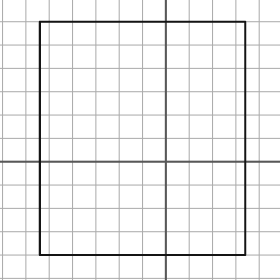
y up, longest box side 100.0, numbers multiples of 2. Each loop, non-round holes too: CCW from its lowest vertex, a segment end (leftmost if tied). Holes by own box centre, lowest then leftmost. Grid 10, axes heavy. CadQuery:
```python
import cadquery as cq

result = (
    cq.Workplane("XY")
    .moveTo(-54.0, -40.0)
    .lineTo(34.0, -40.0)
    .lineTo(34.0, 60.0)
    .lineTo(-54.0, 60.0)
    .close()
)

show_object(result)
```